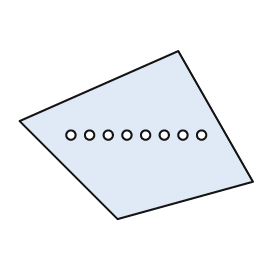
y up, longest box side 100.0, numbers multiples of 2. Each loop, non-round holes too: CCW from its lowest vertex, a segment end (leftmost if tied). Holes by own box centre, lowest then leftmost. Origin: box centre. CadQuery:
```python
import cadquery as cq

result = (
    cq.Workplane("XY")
    .moveTo(-8.0, -36.0)
    .lineTo(50.0, -20.0)
    .lineTo(18.0, 36.0)
    .lineTo(-50.0, 6.0)
    .close()
    .moveTo(-28.0, 0.0)
    .circle(2.0)
    .moveTo(-20.0, 0.0)
    .circle(2.0)
    .moveTo(-12.0, 0.0)
    .circle(2.0)
    .moveTo(-4.0, 0.0)
    .circle(2.0)
    .moveTo(4.0, 0.0)
    .circle(2.0)
    .moveTo(12.0, 0.0)
    .circle(2.0)
    .moveTo(20.0, 0.0)
    .circle(2.0)
    .moveTo(28.0, 0.0)
    .circle(2.0)
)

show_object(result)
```